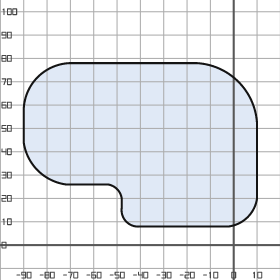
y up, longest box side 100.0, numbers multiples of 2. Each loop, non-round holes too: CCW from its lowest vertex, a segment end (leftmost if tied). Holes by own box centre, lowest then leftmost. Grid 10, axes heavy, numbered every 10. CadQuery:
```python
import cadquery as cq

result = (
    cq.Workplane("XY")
    .moveTo(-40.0, 8.0)
    .lineTo(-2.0, 8.0)
    .threePointArc((6.0, 12.0), (10.0, 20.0))
    .lineTo(10.0, 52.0)
    .threePointArc((2.0, 70.0), (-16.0, 78.0))
    .lineTo(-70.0, 78.0)
    .threePointArc((-84.0, 72.0), (-90.0, 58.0))
    .lineTo(-90.0, 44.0)
    .threePointArc((-84.0, 32.0), (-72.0, 26.0))
    .lineTo(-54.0, 26.0)
    .threePointArc((-50.0, 24.0), (-48.0, 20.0))
    .lineTo(-48.0, 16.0)
    .threePointArc((-46.0, 10.0), (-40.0, 8.0))
    .close()
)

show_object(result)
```